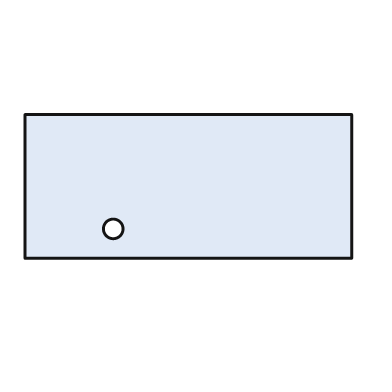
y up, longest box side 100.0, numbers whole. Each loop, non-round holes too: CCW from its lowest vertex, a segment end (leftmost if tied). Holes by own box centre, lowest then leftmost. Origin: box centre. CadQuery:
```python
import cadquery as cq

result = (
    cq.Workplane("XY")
    .moveTo(-50.0, -22.0)
    .lineTo(50.0, -22.0)
    .lineTo(50.0, 22.0)
    .lineTo(-50.0, 22.0)
    .close()
    .moveTo(-23.0, -13.0)
    .circle(3.0)
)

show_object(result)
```